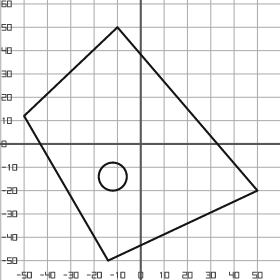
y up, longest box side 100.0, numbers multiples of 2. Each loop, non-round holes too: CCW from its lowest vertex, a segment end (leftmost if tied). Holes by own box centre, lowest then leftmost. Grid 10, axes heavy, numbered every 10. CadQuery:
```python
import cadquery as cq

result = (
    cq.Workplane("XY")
    .moveTo(-14.0, -50.0)
    .lineTo(50.0, -20.0)
    .lineTo(-10.0, 50.0)
    .lineTo(-50.0, 12.0)
    .close()
    .moveTo(-12.0, -14.0)
    .circle(6.0)
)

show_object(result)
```